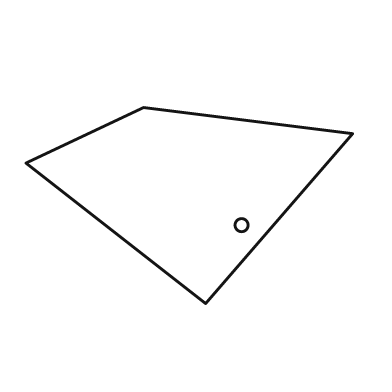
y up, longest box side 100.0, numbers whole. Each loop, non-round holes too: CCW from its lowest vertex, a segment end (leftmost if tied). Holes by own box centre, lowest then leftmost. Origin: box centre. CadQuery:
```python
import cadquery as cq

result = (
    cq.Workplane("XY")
    .moveTo(5.0, -30.0)
    .lineTo(50.0, 22.0)
    .lineTo(-14.0, 30.0)
    .lineTo(-50.0, 13.0)
    .close()
    .moveTo(16.0, -6.0)
    .circle(2.0)
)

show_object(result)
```